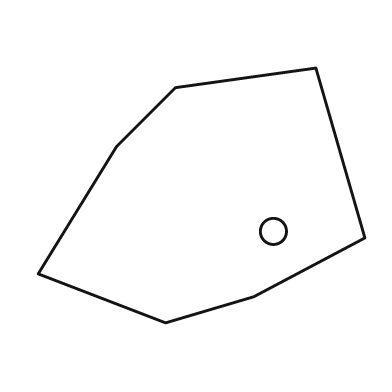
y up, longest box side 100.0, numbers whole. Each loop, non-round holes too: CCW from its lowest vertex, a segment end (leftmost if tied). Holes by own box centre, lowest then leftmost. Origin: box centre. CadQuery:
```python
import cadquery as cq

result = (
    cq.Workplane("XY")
    .moveTo(-11.0, -39.0)
    .lineTo(16.0, -31.0)
    .lineTo(50.0, -13.0)
    .lineTo(35.0, 39.0)
    .lineTo(-8.0, 33.0)
    .lineTo(-26.0, 15.0)
    .lineTo(-50.0, -24.0)
    .close()
    .moveTo(22.0, -11.0)
    .circle(4.0)
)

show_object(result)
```